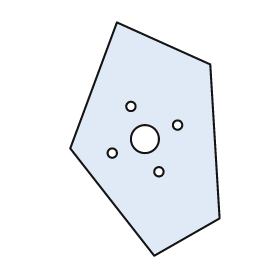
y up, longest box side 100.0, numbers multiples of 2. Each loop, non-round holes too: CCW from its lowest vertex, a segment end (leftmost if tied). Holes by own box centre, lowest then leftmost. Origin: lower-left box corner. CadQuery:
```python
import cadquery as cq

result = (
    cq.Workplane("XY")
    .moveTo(36.0, 0.0)
    .lineTo(64.0, 16.0)
    .lineTo(60.0, 82.0)
    .lineTo(20.0, 100.0)
    .lineTo(0.0, 46.0)
    .close()
    .moveTo(38.0, 36.0)
    .circle(2.0)
    .moveTo(18.0, 44.0)
    .circle(2.0)
    .moveTo(32.0, 50.0)
    .circle(6.0)
    .moveTo(46.0, 56.0)
    .circle(2.0)
    .moveTo(26.0, 64.0)
    .circle(2.0)
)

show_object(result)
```